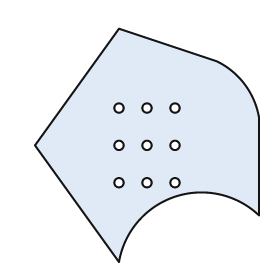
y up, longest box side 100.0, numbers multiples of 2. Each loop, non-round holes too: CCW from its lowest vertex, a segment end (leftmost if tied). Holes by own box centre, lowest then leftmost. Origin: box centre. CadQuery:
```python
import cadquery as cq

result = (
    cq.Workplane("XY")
    .moveTo(-12.0, -50.0)
    .threePointArc((12.0, -22.0), (48.0, -30.0))
    .lineTo(48.0, 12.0)
    .threePointArc((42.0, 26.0), (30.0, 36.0))
    .lineTo(-12.0, 50.0)
    .lineTo(-48.0, 0.0)
    .close()
    .moveTo(-12.0, -16.0)
    .circle(2.0)
    .moveTo(0.0, -16.0)
    .circle(2.0)
    .moveTo(12.0, -16.0)
    .circle(2.0)
    .moveTo(-12.0, 0.0)
    .circle(2.0)
    .moveTo(0.0, 0.0)
    .circle(2.0)
    .moveTo(12.0, 0.0)
    .circle(2.0)
    .moveTo(-12.0, 16.0)
    .circle(2.0)
    .moveTo(0.0, 16.0)
    .circle(2.0)
    .moveTo(12.0, 16.0)
    .circle(2.0)
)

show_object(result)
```